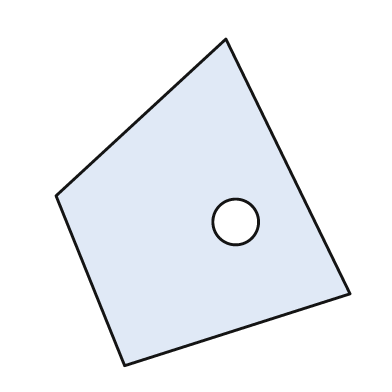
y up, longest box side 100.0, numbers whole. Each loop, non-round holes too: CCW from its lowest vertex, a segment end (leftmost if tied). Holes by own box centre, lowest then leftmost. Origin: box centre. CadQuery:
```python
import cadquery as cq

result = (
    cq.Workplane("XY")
    .moveTo(-24.0, -50.0)
    .lineTo(45.0, -28.0)
    .lineTo(7.0, 50.0)
    .lineTo(-45.0, 2.0)
    .close()
    .moveTo(10.0, -6.0)
    .circle(7.0)
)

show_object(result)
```